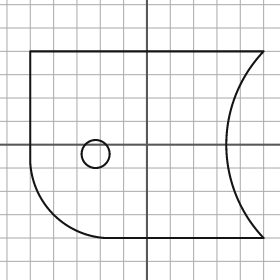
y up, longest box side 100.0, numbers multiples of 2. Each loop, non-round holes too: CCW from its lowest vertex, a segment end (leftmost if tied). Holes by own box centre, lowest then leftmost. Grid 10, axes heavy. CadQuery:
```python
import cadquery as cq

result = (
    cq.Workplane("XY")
    .moveTo(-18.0, -40.0)
    .lineTo(50.0, -40.0)
    .threePointArc((34.0, 0.0), (50.0, 40.0))
    .lineTo(-50.0, 40.0)
    .lineTo(-50.0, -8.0)
    .threePointArc((-40.0, -30.0), (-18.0, -40.0))
    .close()
    .moveTo(-22.0, -4.0)
    .circle(6.0)
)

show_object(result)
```